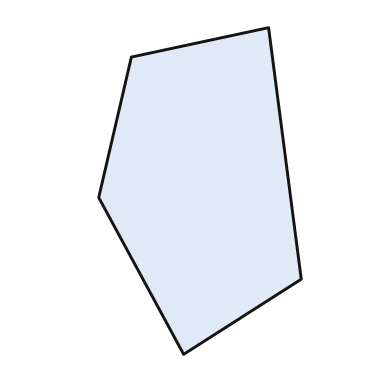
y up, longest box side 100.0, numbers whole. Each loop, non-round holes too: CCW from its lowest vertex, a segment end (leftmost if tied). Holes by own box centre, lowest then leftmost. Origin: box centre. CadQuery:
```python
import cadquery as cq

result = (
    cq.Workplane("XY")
    .moveTo(-5.0, -50.0)
    .lineTo(31.0, -27.0)
    .lineTo(21.0, 50.0)
    .lineTo(-21.0, 41.0)
    .lineTo(-31.0, -2.0)
    .close()
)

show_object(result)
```